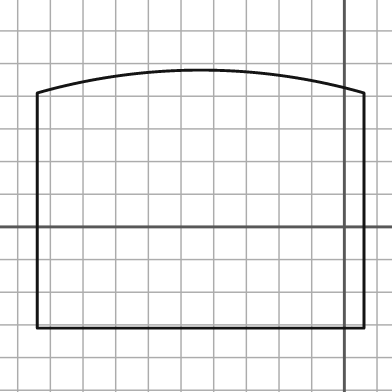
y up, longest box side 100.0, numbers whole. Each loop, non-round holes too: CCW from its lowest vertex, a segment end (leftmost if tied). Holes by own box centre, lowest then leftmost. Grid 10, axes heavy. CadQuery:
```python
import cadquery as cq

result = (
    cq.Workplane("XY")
    .moveTo(-94.0, -31.0)
    .lineTo(6.0, -31.0)
    .lineTo(6.0, 41.0)
    .threePointArc((-44.0, 48.0), (-94.0, 41.0))
    .close()
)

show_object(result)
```